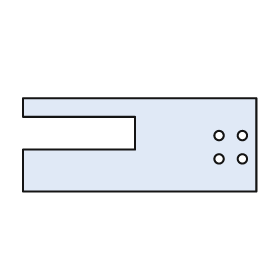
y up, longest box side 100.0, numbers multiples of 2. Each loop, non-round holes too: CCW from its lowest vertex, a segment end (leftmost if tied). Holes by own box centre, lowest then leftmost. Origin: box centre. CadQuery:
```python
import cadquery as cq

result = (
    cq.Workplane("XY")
    .moveTo(-50.0, -20.0)
    .lineTo(50.0, -20.0)
    .lineTo(50.0, 20.0)
    .lineTo(-50.0, 20.0)
    .lineTo(-50.0, 12.0)
    .lineTo(-2.0, 12.0)
    .lineTo(-2.0, -2.0)
    .lineTo(-50.0, -2.0)
    .close()
    .moveTo(34.0, -6.0)
    .circle(2.0)
    .moveTo(44.0, -6.0)
    .circle(2.0)
    .moveTo(34.0, 4.0)
    .circle(2.0)
    .moveTo(44.0, 4.0)
    .circle(2.0)
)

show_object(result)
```